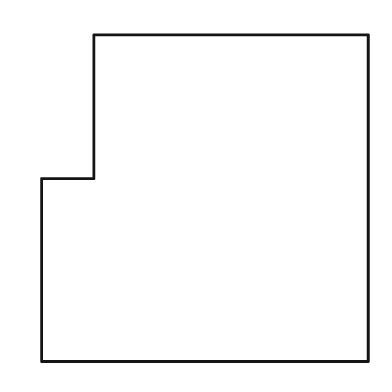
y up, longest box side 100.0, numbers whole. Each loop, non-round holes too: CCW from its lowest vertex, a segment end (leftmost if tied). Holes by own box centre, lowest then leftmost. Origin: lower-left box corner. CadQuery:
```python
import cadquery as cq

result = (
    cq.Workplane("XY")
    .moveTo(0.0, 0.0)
    .lineTo(100.0, 0.0)
    .lineTo(100.0, 100.0)
    .lineTo(16.0, 100.0)
    .lineTo(16.0, 56.0)
    .lineTo(0.0, 56.0)
    .close()
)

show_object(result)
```